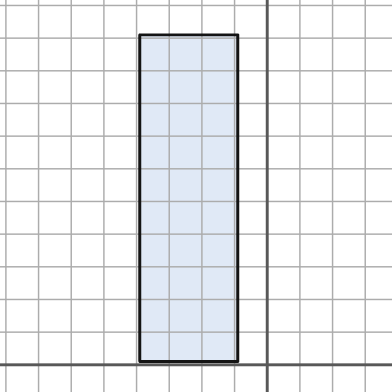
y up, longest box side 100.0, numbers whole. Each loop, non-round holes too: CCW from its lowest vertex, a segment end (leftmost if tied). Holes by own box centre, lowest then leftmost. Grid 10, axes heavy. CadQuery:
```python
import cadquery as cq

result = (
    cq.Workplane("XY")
    .moveTo(-39.0, 1.0)
    .lineTo(-9.0, 1.0)
    .lineTo(-9.0, 101.0)
    .lineTo(-39.0, 101.0)
    .close()
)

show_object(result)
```